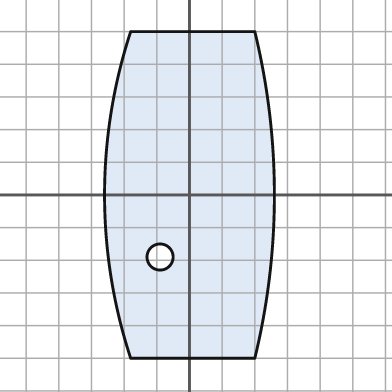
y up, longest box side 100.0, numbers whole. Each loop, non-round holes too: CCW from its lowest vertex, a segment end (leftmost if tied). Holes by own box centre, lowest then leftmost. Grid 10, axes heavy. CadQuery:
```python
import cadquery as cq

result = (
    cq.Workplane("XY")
    .moveTo(-18.0, -50.0)
    .lineTo(20.0, -50.0)
    .threePointArc((26.0, 0.0), (20.0, 50.0))
    .lineTo(-18.0, 50.0)
    .threePointArc((-26.0, 0.0), (-18.0, -50.0))
    .close()
    .moveTo(-9.0, -19.0)
    .circle(4.0)
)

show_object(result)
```